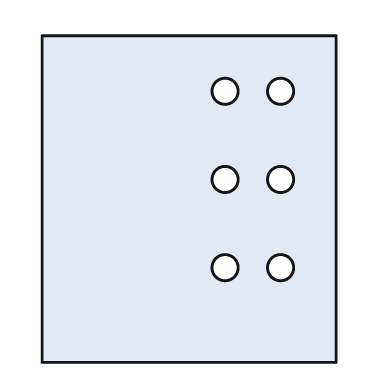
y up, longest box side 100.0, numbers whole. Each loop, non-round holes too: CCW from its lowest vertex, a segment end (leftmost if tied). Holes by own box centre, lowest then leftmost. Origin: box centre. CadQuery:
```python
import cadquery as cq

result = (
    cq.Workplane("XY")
    .moveTo(-45.0, -50.0)
    .lineTo(45.0, -50.0)
    .lineTo(45.0, 50.0)
    .lineTo(-45.0, 50.0)
    .close()
    .moveTo(11.0, -21.0)
    .circle(4.0)
    .moveTo(28.0, -21.0)
    .circle(4.0)
    .moveTo(11.0, 6.0)
    .circle(4.0)
    .moveTo(28.0, 6.0)
    .circle(4.0)
    .moveTo(11.0, 33.0)
    .circle(4.0)
    .moveTo(28.0, 33.0)
    .circle(4.0)
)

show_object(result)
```